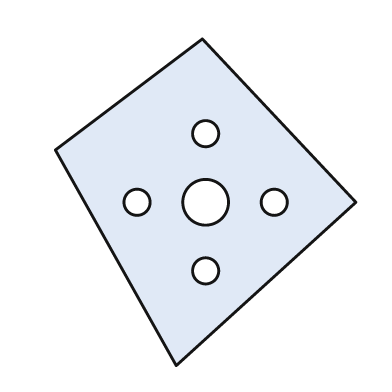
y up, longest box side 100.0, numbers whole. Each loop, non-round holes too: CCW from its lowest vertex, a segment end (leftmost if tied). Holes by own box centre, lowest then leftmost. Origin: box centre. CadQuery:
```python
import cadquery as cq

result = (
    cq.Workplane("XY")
    .moveTo(-9.0, -50.0)
    .lineTo(46.0, 0.0)
    .lineTo(-1.0, 50.0)
    .lineTo(-46.0, 16.0)
    .close()
    .moveTo(0.0, -21.0)
    .circle(4.0)
    .moveTo(-21.0, 0.0)
    .circle(4.0)
    .moveTo(0.0, 0.0)
    .circle(7.0)
    .moveTo(21.0, 0.0)
    .circle(4.0)
    .moveTo(0.0, 21.0)
    .circle(4.0)
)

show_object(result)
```